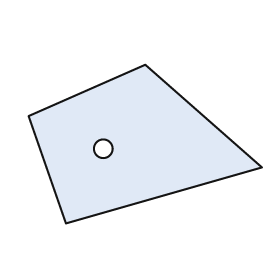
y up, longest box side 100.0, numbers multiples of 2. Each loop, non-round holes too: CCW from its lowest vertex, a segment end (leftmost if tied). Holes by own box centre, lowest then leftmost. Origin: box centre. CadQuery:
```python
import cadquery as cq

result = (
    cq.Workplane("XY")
    .moveTo(-34.0, -34.0)
    .lineTo(50.0, -10.0)
    .lineTo(0.0, 34.0)
    .lineTo(-50.0, 12.0)
    .close()
    .moveTo(-18.0, -2.0)
    .circle(4.0)
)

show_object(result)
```